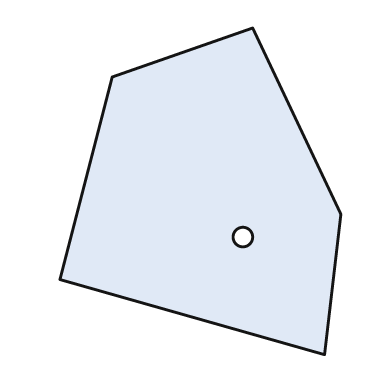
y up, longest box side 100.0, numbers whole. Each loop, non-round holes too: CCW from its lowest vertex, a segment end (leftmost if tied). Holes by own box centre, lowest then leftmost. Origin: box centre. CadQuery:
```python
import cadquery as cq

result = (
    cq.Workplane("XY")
    .moveTo(38.0, -50.0)
    .lineTo(43.0, -7.0)
    .lineTo(16.0, 50.0)
    .lineTo(-27.0, 35.0)
    .lineTo(-43.0, -27.0)
    .close()
    .moveTo(13.0, -14.0)
    .circle(3.0)
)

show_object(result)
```